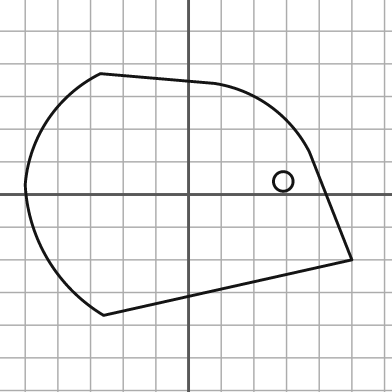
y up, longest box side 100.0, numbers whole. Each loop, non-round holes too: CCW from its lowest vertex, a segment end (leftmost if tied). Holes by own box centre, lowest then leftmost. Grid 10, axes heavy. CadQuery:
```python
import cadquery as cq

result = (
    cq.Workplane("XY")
    .moveTo(-26.0, -37.0)
    .lineTo(50.0, -20.0)
    .lineTo(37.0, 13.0)
    .threePointArc((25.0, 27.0), (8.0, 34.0))
    .lineTo(-27.0, 37.0)
    .threePointArc((-43.0, 23.0), (-50.0, 3.0))
    .threePointArc((-43.0, -20.0), (-26.0, -37.0))
    .close()
    .moveTo(29.0, 4.0)
    .circle(3.0)
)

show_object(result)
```